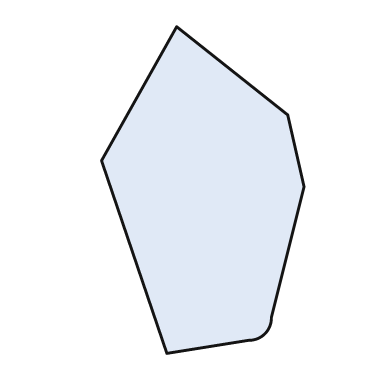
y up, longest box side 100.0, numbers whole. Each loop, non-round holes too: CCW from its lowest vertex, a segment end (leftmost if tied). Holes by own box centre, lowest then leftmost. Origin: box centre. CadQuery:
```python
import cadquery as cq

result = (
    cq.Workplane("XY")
    .moveTo(-11.0, -50.0)
    .lineTo(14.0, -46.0)
    .threePointArc((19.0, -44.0), (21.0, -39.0))
    .lineTo(31.0, 1.0)
    .lineTo(26.0, 23.0)
    .lineTo(-8.0, 50.0)
    .lineTo(-31.0, 9.0)
    .close()
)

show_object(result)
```